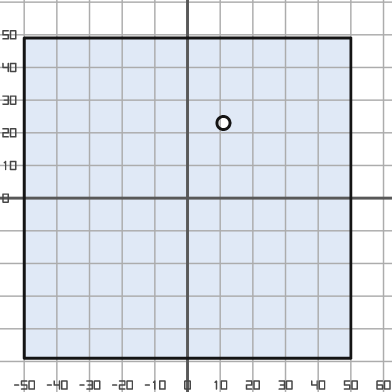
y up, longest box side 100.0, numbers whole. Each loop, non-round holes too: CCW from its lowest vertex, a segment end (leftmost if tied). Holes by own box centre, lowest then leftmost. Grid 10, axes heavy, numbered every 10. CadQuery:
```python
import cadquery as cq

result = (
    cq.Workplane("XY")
    .moveTo(-50.0, -49.0)
    .lineTo(50.0, -49.0)
    .lineTo(50.0, 49.0)
    .lineTo(-50.0, 49.0)
    .close()
    .moveTo(11.0, 23.0)
    .circle(2.0)
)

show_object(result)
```